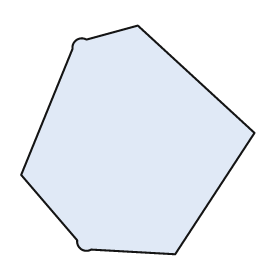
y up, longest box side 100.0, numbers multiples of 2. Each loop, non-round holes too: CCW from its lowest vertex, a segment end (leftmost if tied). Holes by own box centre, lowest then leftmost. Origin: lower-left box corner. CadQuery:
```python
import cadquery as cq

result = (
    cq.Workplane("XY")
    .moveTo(66.0, 0.0)
    .lineTo(100.0, 52.0)
    .lineTo(50.0, 98.0)
    .lineTo(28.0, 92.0)
    .threePointArc((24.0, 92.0), (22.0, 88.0))
    .lineTo(0.0, 34.0)
    .lineTo(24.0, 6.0)
    .threePointArc((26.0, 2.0), (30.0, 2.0))
    .close()
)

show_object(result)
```